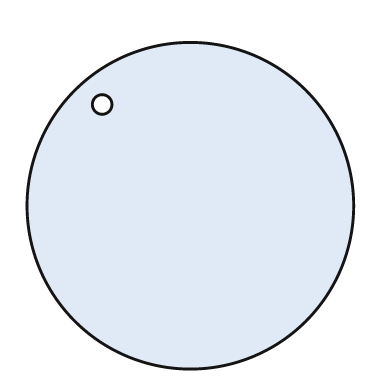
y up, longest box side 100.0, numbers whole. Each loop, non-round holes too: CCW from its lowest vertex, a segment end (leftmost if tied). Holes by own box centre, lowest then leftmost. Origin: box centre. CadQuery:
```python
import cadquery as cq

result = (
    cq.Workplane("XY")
    .moveTo(0.0, 0.0)
    .circle(50.0)
    .moveTo(-27.0, 31.0)
    .circle(3.0)
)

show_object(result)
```